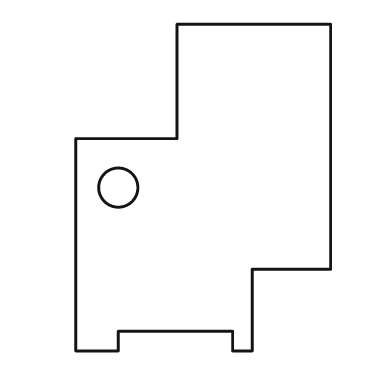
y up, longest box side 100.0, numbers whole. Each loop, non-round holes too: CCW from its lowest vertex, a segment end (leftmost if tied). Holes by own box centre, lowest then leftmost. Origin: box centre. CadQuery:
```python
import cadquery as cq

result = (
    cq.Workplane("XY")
    .moveTo(-39.0, -50.0)
    .lineTo(-26.0, -50.0)
    .lineTo(-26.0, -44.0)
    .lineTo(9.0, -44.0)
    .lineTo(9.0, -50.0)
    .lineTo(15.0, -50.0)
    .lineTo(15.0, -25.0)
    .lineTo(39.0, -25.0)
    .lineTo(39.0, 50.0)
    .lineTo(-8.0, 50.0)
    .lineTo(-8.0, 15.0)
    .lineTo(-39.0, 15.0)
    .close()
    .moveTo(-26.0, 0.0)
    .circle(6.0)
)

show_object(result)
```